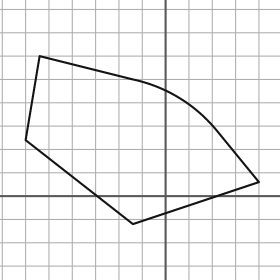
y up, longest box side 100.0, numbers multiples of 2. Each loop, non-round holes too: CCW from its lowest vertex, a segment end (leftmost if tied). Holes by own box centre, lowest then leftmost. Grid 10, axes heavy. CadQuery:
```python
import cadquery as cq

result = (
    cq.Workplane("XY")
    .moveTo(-14.0, -12.0)
    .lineTo(40.0, 6.0)
    .lineTo(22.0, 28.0)
    .threePointArc((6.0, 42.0), (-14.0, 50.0))
    .lineTo(-54.0, 60.0)
    .lineTo(-60.0, 24.0)
    .close()
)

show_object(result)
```